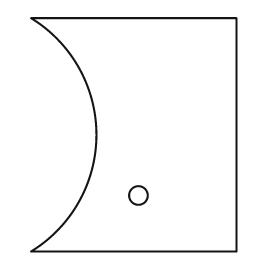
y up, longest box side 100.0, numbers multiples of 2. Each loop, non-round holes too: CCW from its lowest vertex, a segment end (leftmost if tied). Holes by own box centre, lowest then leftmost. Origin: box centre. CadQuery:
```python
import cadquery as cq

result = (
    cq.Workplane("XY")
    .moveTo(-44.0, -50.0)
    .lineTo(44.0, -50.0)
    .lineTo(44.0, 50.0)
    .lineTo(-44.0, 50.0)
    .threePointArc((-16.0, 0.0), (-44.0, -50.0))
    .close()
    .moveTo(2.0, -26.0)
    .circle(4.0)
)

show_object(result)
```